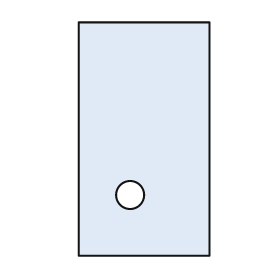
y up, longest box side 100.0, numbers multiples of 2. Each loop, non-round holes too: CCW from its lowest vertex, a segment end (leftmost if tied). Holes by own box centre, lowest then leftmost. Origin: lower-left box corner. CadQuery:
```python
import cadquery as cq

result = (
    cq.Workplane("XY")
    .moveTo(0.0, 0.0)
    .lineTo(56.0, 0.0)
    .lineTo(56.0, 100.0)
    .lineTo(0.0, 100.0)
    .close()
    .moveTo(22.0, 26.0)
    .circle(6.0)
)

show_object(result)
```